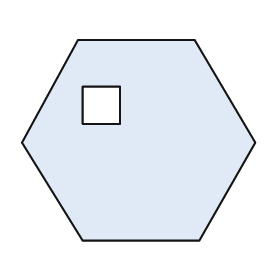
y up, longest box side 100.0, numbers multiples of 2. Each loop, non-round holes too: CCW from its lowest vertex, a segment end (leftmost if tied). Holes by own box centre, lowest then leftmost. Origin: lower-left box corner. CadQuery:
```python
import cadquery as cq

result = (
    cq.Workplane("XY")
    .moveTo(26.0, 0.0)
    .lineTo(76.0, 0.0)
    .lineTo(100.0, 42.0)
    .lineTo(74.0, 86.0)
    .lineTo(24.0, 86.0)
    .lineTo(0.0, 42.0)
    .close()
    .moveTo(26.0, 50.0)
    .lineTo(42.0, 50.0)
    .lineTo(42.0, 66.0)
    .lineTo(26.0, 66.0)
    .close()
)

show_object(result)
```